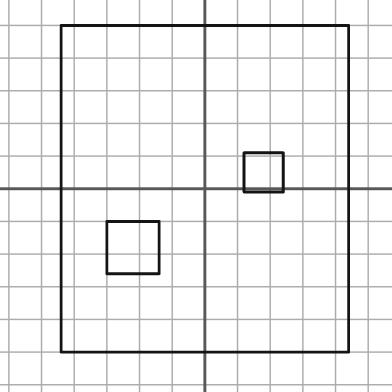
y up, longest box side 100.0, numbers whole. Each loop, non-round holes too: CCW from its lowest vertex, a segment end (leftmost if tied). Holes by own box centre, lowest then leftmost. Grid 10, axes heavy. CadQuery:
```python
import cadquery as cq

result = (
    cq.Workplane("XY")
    .moveTo(-44.0, -50.0)
    .lineTo(44.0, -50.0)
    .lineTo(44.0, 50.0)
    .lineTo(-44.0, 50.0)
    .close()
    .moveTo(-30.0, -26.0)
    .lineTo(-14.0, -26.0)
    .lineTo(-14.0, -10.0)
    .lineTo(-30.0, -10.0)
    .close()
    .moveTo(12.0, -1.0)
    .lineTo(24.0, -1.0)
    .lineTo(24.0, 11.0)
    .lineTo(12.0, 11.0)
    .close()
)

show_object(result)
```